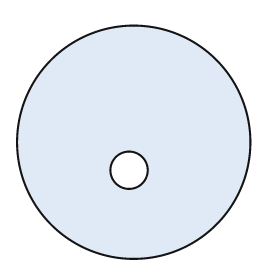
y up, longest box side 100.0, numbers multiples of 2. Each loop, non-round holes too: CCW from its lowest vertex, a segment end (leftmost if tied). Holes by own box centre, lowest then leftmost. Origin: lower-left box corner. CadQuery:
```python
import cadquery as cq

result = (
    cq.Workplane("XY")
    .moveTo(50.0, 50.0)
    .circle(50.0)
    .moveTo(48.0, 38.0)
    .circle(8.0)
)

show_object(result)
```